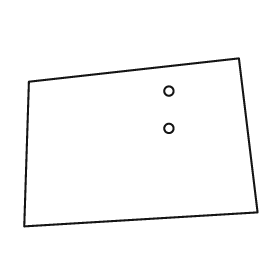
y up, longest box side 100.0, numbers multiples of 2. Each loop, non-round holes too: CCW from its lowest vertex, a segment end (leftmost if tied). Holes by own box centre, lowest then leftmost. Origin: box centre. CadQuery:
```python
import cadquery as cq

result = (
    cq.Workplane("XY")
    .moveTo(-50.0, -36.0)
    .lineTo(50.0, -30.0)
    .lineTo(42.0, 36.0)
    .lineTo(-48.0, 26.0)
    .close()
    .moveTo(12.0, 6.0)
    .circle(2.0)
    .moveTo(12.0, 22.0)
    .circle(2.0)
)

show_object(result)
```